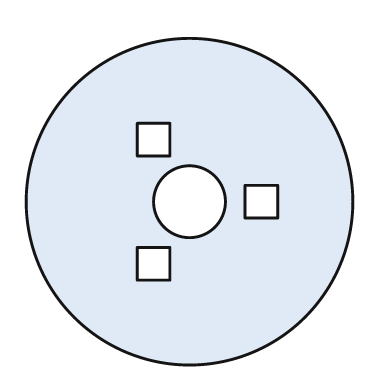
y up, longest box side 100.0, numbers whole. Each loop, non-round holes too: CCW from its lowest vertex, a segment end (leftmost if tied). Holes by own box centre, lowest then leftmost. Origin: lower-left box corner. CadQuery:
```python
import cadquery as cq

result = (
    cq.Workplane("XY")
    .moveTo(50.0, 50.0)
    .circle(50.0)
    .moveTo(34.0, 26.0)
    .lineTo(44.0, 26.0)
    .lineTo(44.0, 36.0)
    .lineTo(34.0, 36.0)
    .close()
    .moveTo(50.0, 50.0)
    .circle(11.0)
    .moveTo(67.0, 45.0)
    .lineTo(77.0, 45.0)
    .lineTo(77.0, 55.0)
    .lineTo(67.0, 55.0)
    .close()
    .moveTo(34.0, 64.0)
    .lineTo(44.0, 64.0)
    .lineTo(44.0, 74.0)
    .lineTo(34.0, 74.0)
    .close()
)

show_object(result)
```